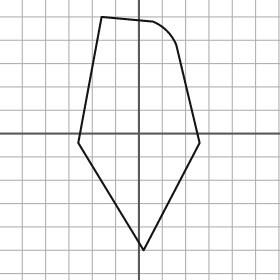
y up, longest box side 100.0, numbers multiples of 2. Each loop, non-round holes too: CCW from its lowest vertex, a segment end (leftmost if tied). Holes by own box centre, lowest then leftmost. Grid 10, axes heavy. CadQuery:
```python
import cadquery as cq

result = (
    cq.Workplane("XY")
    .moveTo(2.0, -50.0)
    .lineTo(26.0, -4.0)
    .lineTo(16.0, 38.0)
    .threePointArc((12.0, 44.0), (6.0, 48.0))
    .lineTo(-16.0, 50.0)
    .lineTo(-26.0, -4.0)
    .close()
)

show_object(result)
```